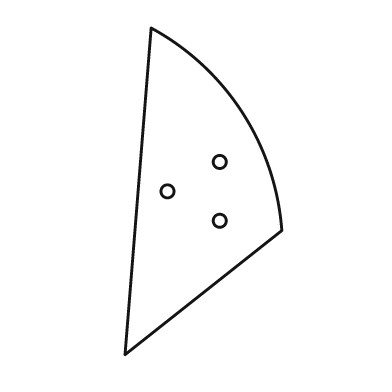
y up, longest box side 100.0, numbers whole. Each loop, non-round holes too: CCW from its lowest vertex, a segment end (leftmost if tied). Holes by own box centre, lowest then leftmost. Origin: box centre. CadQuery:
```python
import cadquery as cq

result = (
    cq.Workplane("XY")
    .moveTo(-24.0, -50.0)
    .lineTo(24.0, -12.0)
    .threePointArc((12.0, 24.0), (-16.0, 50.0))
    .close()
    .moveTo(5.0, -9.0)
    .circle(2.0)
    .moveTo(-11.0, 0.0)
    .circle(2.0)
    .moveTo(5.0, 9.0)
    .circle(2.0)
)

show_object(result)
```